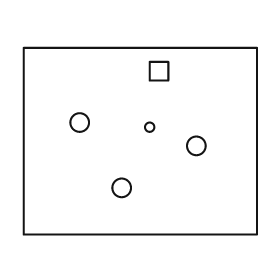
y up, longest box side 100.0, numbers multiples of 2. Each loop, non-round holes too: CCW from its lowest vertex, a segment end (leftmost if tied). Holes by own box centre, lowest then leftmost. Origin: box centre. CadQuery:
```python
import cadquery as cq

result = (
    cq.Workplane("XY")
    .moveTo(-50.0, -40.0)
    .lineTo(50.0, -40.0)
    .lineTo(50.0, 40.0)
    .lineTo(-50.0, 40.0)
    .close()
    .moveTo(-8.0, -20.0)
    .circle(4.0)
    .moveTo(24.0, -2.0)
    .circle(4.0)
    .moveTo(4.0, 6.0)
    .circle(2.0)
    .moveTo(-26.0, 8.0)
    .circle(4.0)
    .moveTo(4.0, 26.0)
    .lineTo(12.0, 26.0)
    .lineTo(12.0, 34.0)
    .lineTo(4.0, 34.0)
    .close()
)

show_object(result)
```